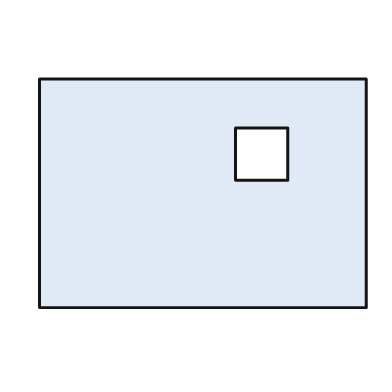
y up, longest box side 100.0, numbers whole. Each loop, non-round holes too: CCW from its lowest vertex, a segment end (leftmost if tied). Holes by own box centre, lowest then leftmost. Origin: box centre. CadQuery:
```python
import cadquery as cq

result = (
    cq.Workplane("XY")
    .moveTo(-50.0, -35.0)
    .lineTo(50.0, -35.0)
    .lineTo(50.0, 35.0)
    .lineTo(-50.0, 35.0)
    .close()
    .moveTo(10.0, 4.0)
    .lineTo(26.0, 4.0)
    .lineTo(26.0, 20.0)
    .lineTo(10.0, 20.0)
    .close()
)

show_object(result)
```